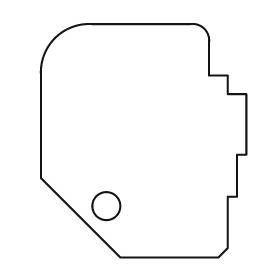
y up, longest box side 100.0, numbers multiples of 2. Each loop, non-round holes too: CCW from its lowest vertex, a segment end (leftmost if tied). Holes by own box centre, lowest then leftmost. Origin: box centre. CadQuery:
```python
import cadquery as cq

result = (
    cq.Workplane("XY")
    .moveTo(-10.0, -50.0)
    .lineTo(32.0, -50.0)
    .lineTo(36.0, -46.0)
    .lineTo(36.0, -24.0)
    .lineTo(40.0, -24.0)
    .lineTo(40.0, -6.0)
    .lineTo(44.0, -6.0)
    .lineTo(44.0, 20.0)
    .lineTo(36.0, 20.0)
    .lineTo(36.0, 28.0)
    .lineTo(28.0, 28.0)
    .lineTo(28.0, 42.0)
    .threePointArc((26.0, 48.0), (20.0, 50.0))
    .lineTo(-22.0, 50.0)
    .threePointArc((-38.0, 44.0), (-44.0, 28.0))
    .lineTo(-44.0, -16.0)
    .close()
    .moveTo(-16.0, -28.0)
    .circle(6.0)
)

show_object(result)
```